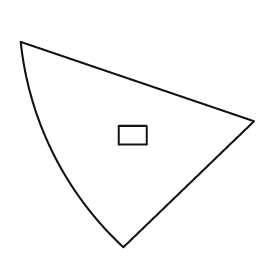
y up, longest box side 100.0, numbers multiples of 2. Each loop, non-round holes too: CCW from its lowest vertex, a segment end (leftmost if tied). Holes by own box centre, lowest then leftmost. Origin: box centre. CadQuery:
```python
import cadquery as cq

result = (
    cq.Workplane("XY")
    .moveTo(-6.0, -44.0)
    .lineTo(50.0, 10.0)
    .lineTo(-50.0, 44.0)
    .threePointArc((-36.0, -4.0), (-6.0, -44.0))
    .close()
    .moveTo(-8.0, 0.0)
    .lineTo(4.0, 0.0)
    .lineTo(4.0, 8.0)
    .lineTo(-8.0, 8.0)
    .close()
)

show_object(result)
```